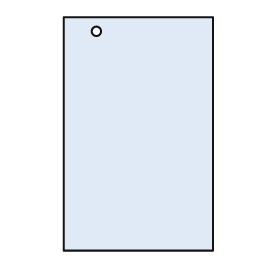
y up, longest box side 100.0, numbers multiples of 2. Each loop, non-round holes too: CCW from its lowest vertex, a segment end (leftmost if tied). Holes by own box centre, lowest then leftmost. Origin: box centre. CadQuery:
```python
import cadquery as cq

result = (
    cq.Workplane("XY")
    .moveTo(-32.0, -50.0)
    .lineTo(32.0, -50.0)
    .lineTo(32.0, 50.0)
    .lineTo(-32.0, 50.0)
    .close()
    .moveTo(-18.0, 44.0)
    .circle(2.0)
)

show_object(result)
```